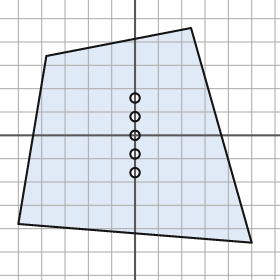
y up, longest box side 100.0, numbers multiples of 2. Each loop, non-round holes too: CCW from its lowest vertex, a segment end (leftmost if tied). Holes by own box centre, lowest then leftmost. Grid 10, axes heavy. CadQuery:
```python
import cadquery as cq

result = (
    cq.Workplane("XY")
    .moveTo(50.0, -46.0)
    .lineTo(24.0, 46.0)
    .lineTo(-38.0, 34.0)
    .lineTo(-50.0, -38.0)
    .close()
    .moveTo(0.0, -16.0)
    .circle(2.0)
    .moveTo(0.0, -8.0)
    .circle(2.0)
    .moveTo(0.0, 0.0)
    .circle(2.0)
    .moveTo(0.0, 8.0)
    .circle(2.0)
    .moveTo(0.0, 16.0)
    .circle(2.0)
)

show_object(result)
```